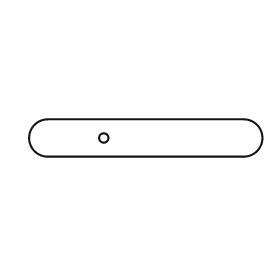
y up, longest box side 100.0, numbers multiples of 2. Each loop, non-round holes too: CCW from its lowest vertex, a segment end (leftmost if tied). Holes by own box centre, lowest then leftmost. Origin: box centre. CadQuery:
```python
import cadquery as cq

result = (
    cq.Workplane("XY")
    .moveTo(-42.0, -8.0)
    .lineTo(42.0, -8.0)
    .threePointArc((50.0, 0.0), (42.0, 8.0))
    .lineTo(-42.0, 8.0)
    .threePointArc((-50.0, 0.0), (-42.0, -8.0))
    .close()
    .moveTo(-18.0, 0.0)
    .circle(2.0)
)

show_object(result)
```